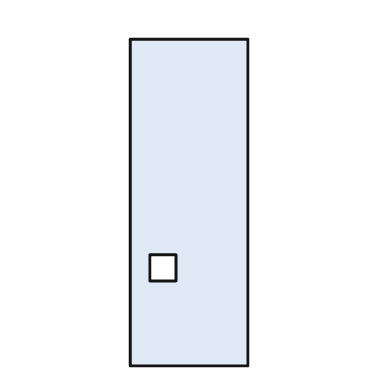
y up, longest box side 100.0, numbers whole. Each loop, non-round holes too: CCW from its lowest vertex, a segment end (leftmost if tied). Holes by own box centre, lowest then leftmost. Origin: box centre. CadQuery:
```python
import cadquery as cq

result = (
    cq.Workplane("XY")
    .moveTo(-18.0, -50.0)
    .lineTo(18.0, -50.0)
    .lineTo(18.0, 50.0)
    .lineTo(-18.0, 50.0)
    .close()
    .moveTo(-12.0, -24.0)
    .lineTo(-4.0, -24.0)
    .lineTo(-4.0, -16.0)
    .lineTo(-12.0, -16.0)
    .close()
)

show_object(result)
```